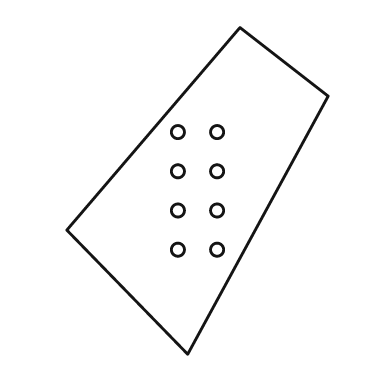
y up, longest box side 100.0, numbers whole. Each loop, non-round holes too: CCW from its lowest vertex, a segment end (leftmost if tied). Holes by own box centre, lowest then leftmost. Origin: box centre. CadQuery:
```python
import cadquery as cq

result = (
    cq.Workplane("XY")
    .moveTo(-3.0, -50.0)
    .lineTo(40.0, 29.0)
    .lineTo(13.0, 50.0)
    .lineTo(-40.0, -12.0)
    .close()
    .moveTo(-6.0, -18.0)
    .circle(2.0)
    .moveTo(6.0, -18.0)
    .circle(2.0)
    .moveTo(-6.0, -6.0)
    .circle(2.0)
    .moveTo(6.0, -6.0)
    .circle(2.0)
    .moveTo(-6.0, 6.0)
    .circle(2.0)
    .moveTo(6.0, 6.0)
    .circle(2.0)
    .moveTo(-6.0, 18.0)
    .circle(2.0)
    .moveTo(6.0, 18.0)
    .circle(2.0)
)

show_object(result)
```